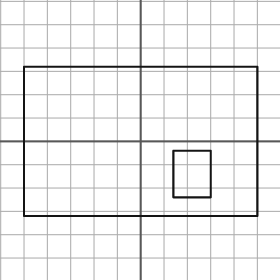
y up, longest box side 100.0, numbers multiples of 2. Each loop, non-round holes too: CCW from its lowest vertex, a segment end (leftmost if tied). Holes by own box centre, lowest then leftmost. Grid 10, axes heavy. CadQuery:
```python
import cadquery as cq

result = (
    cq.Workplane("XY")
    .moveTo(-50.0, -32.0)
    .lineTo(50.0, -32.0)
    .lineTo(50.0, 32.0)
    .lineTo(-50.0, 32.0)
    .close()
    .moveTo(14.0, -24.0)
    .lineTo(30.0, -24.0)
    .lineTo(30.0, -4.0)
    .lineTo(14.0, -4.0)
    .close()
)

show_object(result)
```